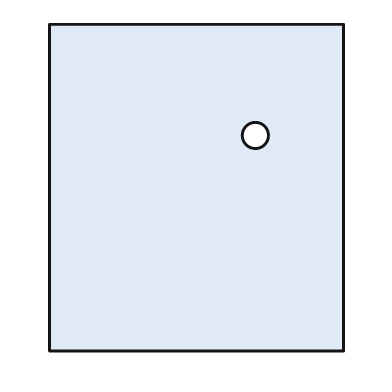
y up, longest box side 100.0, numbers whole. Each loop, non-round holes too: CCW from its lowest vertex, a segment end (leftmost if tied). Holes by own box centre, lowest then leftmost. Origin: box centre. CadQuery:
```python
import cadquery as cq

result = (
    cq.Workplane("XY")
    .moveTo(-45.0, -50.0)
    .lineTo(45.0, -50.0)
    .lineTo(45.0, 50.0)
    .lineTo(-45.0, 50.0)
    .close()
    .moveTo(18.0, 16.0)
    .circle(4.0)
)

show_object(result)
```